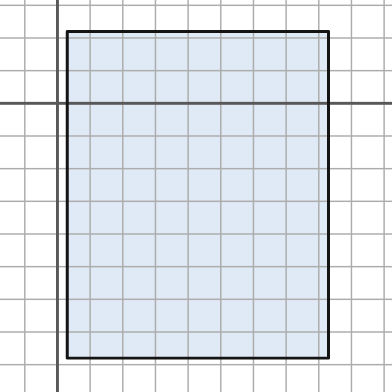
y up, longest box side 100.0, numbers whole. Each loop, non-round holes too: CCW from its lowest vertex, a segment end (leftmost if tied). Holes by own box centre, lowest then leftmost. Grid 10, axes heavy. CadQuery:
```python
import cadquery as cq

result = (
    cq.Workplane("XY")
    .moveTo(3.0, -78.0)
    .lineTo(83.0, -78.0)
    .lineTo(83.0, 22.0)
    .lineTo(3.0, 22.0)
    .close()
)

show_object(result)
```